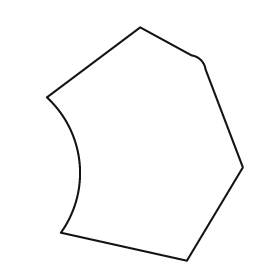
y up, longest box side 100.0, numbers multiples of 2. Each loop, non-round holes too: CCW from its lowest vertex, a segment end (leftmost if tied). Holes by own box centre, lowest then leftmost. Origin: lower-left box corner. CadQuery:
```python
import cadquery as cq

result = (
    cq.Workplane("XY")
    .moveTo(60.0, 0.0)
    .lineTo(84.0, 40.0)
    .lineTo(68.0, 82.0)
    .threePointArc((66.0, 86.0), (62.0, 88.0))
    .lineTo(40.0, 100.0)
    .lineTo(0.0, 70.0)
    .threePointArc((14.0, 42.0), (6.0, 12.0))
    .close()
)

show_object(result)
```